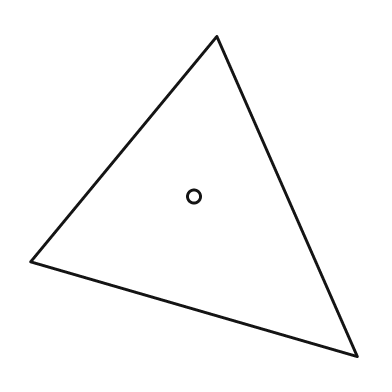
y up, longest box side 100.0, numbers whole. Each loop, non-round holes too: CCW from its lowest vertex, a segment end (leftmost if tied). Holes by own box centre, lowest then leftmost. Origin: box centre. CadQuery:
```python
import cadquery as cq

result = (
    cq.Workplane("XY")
    .moveTo(50.0, -49.0)
    .lineTo(7.0, 49.0)
    .lineTo(-50.0, -20.0)
    .close()
    .moveTo(0.0, 0.0)
    .circle(2.0)
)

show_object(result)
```